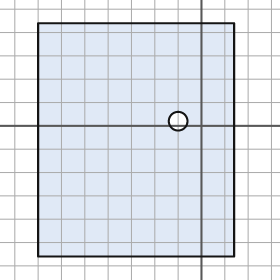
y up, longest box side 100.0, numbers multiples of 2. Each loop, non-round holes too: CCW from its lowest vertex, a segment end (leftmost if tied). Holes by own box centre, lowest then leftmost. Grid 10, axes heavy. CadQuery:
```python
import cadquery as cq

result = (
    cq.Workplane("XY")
    .moveTo(-70.0, -56.0)
    .lineTo(14.0, -56.0)
    .lineTo(14.0, 44.0)
    .lineTo(-70.0, 44.0)
    .close()
    .moveTo(-10.0, 2.0)
    .circle(4.0)
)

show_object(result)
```